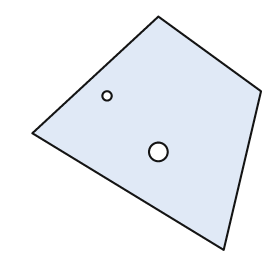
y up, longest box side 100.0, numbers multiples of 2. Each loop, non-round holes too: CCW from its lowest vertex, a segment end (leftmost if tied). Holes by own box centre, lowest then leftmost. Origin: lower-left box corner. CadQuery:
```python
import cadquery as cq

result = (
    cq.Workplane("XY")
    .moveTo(82.0, 0.0)
    .lineTo(98.0, 68.0)
    .lineTo(54.0, 100.0)
    .lineTo(0.0, 50.0)
    .close()
    .moveTo(54.0, 42.0)
    .circle(4.0)
    .moveTo(32.0, 66.0)
    .circle(2.0)
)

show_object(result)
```